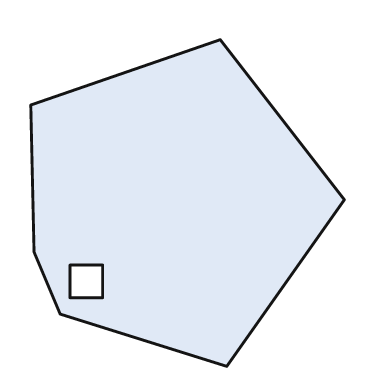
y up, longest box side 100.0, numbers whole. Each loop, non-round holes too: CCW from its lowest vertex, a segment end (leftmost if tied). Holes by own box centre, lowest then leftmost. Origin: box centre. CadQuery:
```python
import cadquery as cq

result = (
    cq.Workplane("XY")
    .moveTo(12.0, -50.0)
    .lineTo(48.0, 1.0)
    .lineTo(10.0, 50.0)
    .lineTo(-48.0, 30.0)
    .lineTo(-47.0, -15.0)
    .lineTo(-39.0, -34.0)
    .close()
    .moveTo(-36.0, -29.0)
    .lineTo(-26.0, -29.0)
    .lineTo(-26.0, -19.0)
    .lineTo(-36.0, -19.0)
    .close()
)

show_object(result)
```